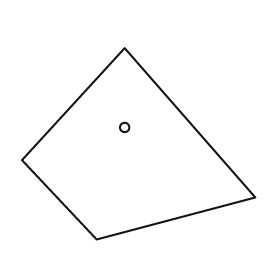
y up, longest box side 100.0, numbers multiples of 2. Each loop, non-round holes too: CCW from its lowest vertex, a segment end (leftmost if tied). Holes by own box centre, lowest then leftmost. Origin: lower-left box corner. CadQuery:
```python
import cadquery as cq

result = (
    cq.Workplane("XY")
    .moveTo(32.0, 0.0)
    .lineTo(100.0, 18.0)
    .lineTo(44.0, 82.0)
    .lineTo(0.0, 34.0)
    .close()
    .moveTo(44.0, 48.0)
    .circle(2.0)
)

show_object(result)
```